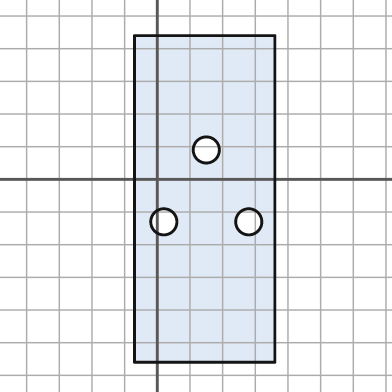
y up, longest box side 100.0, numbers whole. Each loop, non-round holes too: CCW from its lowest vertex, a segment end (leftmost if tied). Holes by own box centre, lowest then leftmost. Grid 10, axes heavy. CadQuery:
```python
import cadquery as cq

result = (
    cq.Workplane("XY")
    .moveTo(-7.0, -56.0)
    .lineTo(36.0, -56.0)
    .lineTo(36.0, 44.0)
    .lineTo(-7.0, 44.0)
    .close()
    .moveTo(2.0, -13.0)
    .circle(4.0)
    .moveTo(28.0, -13.0)
    .circle(4.0)
    .moveTo(15.0, 9.0)
    .circle(4.0)
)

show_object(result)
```